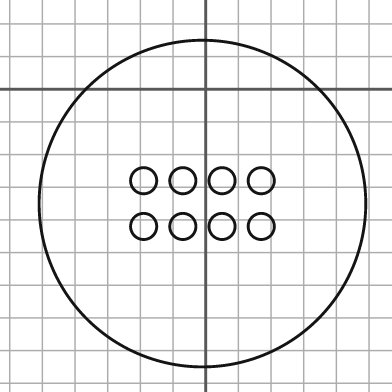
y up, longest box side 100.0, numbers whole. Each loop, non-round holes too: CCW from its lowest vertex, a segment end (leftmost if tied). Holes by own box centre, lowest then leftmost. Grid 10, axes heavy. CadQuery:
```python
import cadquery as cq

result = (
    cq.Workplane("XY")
    .moveTo(-1.0, -35.0)
    .circle(50.0)
    .moveTo(-19.0, -42.0)
    .circle(4.0)
    .moveTo(-7.0, -42.0)
    .circle(4.0)
    .moveTo(5.0, -42.0)
    .circle(4.0)
    .moveTo(17.0, -42.0)
    .circle(4.0)
    .moveTo(-19.0, -28.0)
    .circle(4.0)
    .moveTo(-7.0, -28.0)
    .circle(4.0)
    .moveTo(5.0, -28.0)
    .circle(4.0)
    .moveTo(17.0, -28.0)
    .circle(4.0)
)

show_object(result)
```